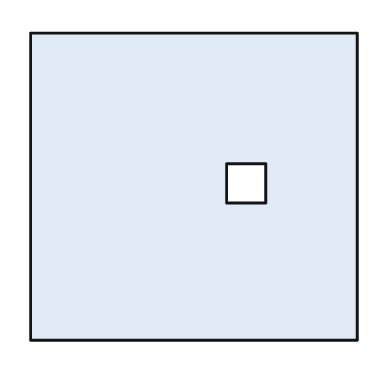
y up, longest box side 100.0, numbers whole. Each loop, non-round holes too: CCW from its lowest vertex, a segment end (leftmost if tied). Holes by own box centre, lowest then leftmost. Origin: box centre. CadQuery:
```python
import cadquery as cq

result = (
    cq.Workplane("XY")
    .moveTo(-50.0, -47.0)
    .lineTo(50.0, -47.0)
    .lineTo(50.0, 47.0)
    .lineTo(-50.0, 47.0)
    .close()
    .moveTo(10.0, -5.0)
    .lineTo(22.0, -5.0)
    .lineTo(22.0, 7.0)
    .lineTo(10.0, 7.0)
    .close()
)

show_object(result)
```